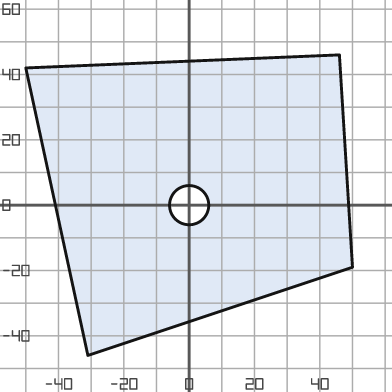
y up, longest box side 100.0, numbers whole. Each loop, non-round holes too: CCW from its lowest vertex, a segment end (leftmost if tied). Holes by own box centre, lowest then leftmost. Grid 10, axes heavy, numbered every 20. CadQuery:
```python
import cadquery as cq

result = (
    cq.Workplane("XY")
    .moveTo(-31.0, -46.0)
    .lineTo(50.0, -19.0)
    .lineTo(46.0, 46.0)
    .lineTo(-50.0, 42.0)
    .close()
    .moveTo(0.0, 0.0)
    .circle(6.0)
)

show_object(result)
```